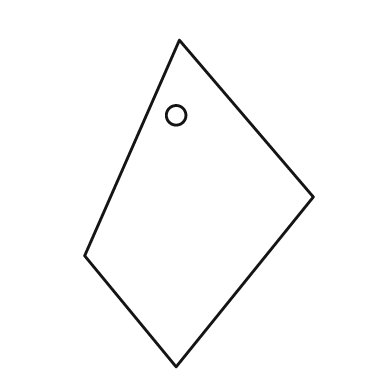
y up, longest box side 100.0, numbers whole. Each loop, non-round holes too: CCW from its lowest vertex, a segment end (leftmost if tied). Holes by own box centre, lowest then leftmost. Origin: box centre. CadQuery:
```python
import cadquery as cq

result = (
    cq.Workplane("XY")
    .moveTo(-7.0, -50.0)
    .lineTo(35.0, 2.0)
    .lineTo(-6.0, 50.0)
    .lineTo(-35.0, -16.0)
    .close()
    .moveTo(-7.0, 27.0)
    .circle(3.0)
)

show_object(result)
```